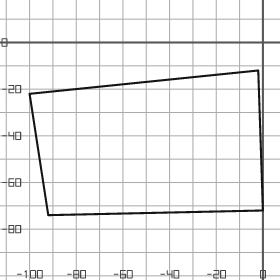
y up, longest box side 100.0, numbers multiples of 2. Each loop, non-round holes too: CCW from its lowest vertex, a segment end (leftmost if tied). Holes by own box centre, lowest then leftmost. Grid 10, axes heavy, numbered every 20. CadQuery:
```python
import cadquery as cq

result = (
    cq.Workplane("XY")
    .moveTo(-92.0, -74.0)
    .lineTo(0.0, -72.0)
    .lineTo(-2.0, -12.0)
    .lineTo(-100.0, -22.0)
    .close()
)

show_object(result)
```